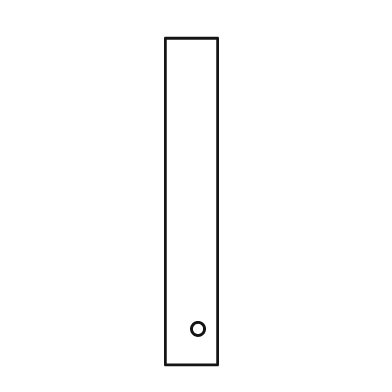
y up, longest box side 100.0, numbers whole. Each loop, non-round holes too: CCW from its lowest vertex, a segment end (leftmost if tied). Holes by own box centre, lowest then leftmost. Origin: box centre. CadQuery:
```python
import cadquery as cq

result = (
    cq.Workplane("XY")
    .moveTo(-8.0, -50.0)
    .lineTo(8.0, -50.0)
    .lineTo(8.0, 50.0)
    .lineTo(-8.0, 50.0)
    .close()
    .moveTo(2.0, -39.0)
    .circle(2.0)
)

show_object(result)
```